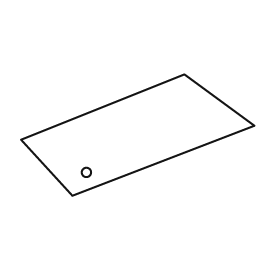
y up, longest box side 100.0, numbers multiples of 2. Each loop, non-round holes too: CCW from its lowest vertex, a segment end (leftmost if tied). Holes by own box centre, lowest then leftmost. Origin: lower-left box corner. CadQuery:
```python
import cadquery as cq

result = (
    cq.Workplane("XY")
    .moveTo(22.0, 0.0)
    .lineTo(100.0, 30.0)
    .lineTo(70.0, 52.0)
    .lineTo(0.0, 24.0)
    .close()
    .moveTo(28.0, 10.0)
    .circle(2.0)
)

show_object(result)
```